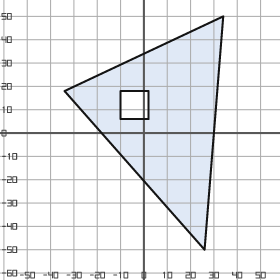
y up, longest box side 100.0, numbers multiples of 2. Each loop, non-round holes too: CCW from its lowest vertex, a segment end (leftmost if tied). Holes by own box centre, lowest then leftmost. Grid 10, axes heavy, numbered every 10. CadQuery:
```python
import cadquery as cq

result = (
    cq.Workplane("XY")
    .moveTo(26.0, -50.0)
    .lineTo(34.0, 50.0)
    .lineTo(-34.0, 18.0)
    .close()
    .moveTo(-10.0, 6.0)
    .lineTo(2.0, 6.0)
    .lineTo(2.0, 18.0)
    .lineTo(-10.0, 18.0)
    .close()
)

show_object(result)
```